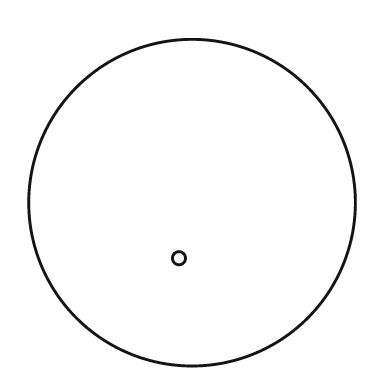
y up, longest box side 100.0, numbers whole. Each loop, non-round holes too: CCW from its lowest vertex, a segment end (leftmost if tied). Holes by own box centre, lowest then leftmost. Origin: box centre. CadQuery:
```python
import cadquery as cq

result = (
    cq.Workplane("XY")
    .moveTo(0.0, 0.0)
    .circle(50.0)
    .moveTo(-4.0, -17.0)
    .circle(2.0)
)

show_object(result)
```